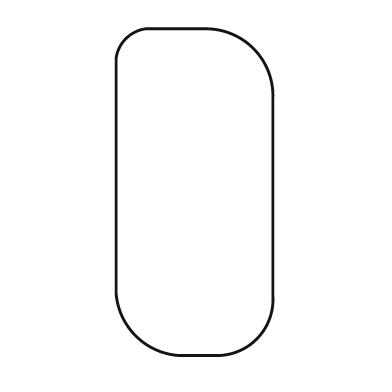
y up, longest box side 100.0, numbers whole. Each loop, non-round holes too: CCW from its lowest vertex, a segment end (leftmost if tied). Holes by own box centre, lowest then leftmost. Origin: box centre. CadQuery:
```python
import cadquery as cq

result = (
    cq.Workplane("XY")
    .moveTo(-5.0, -50.0)
    .lineTo(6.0, -50.0)
    .threePointArc((19.0, -45.0), (24.0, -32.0))
    .lineTo(24.0, 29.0)
    .threePointArc((18.0, 44.0), (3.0, 50.0))
    .lineTo(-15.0, 50.0)
    .threePointArc((-21.0, 47.0), (-24.0, 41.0))
    .lineTo(-24.0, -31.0)
    .threePointArc((-18.0, -44.0), (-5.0, -50.0))
    .close()
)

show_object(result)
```